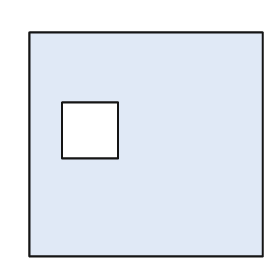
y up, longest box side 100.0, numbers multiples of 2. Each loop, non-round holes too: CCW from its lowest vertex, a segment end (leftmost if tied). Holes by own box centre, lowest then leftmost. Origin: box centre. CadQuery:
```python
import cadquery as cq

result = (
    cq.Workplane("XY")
    .moveTo(-50.0, -48.0)
    .lineTo(50.0, -48.0)
    .lineTo(50.0, 48.0)
    .lineTo(-50.0, 48.0)
    .close()
    .moveTo(-36.0, -6.0)
    .lineTo(-12.0, -6.0)
    .lineTo(-12.0, 18.0)
    .lineTo(-36.0, 18.0)
    .close()
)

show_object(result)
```